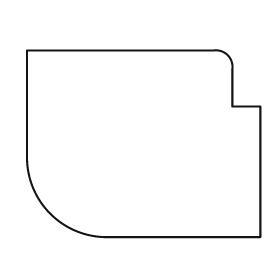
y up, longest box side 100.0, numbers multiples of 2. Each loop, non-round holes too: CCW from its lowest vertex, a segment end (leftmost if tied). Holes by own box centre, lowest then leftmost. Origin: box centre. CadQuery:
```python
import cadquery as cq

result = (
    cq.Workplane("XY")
    .moveTo(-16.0, -40.0)
    .lineTo(50.0, -40.0)
    .lineTo(50.0, 16.0)
    .lineTo(38.0, 16.0)
    .lineTo(38.0, 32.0)
    .threePointArc((36.0, 38.0), (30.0, 40.0))
    .lineTo(-50.0, 40.0)
    .lineTo(-50.0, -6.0)
    .threePointArc((-40.0, -30.0), (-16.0, -40.0))
    .close()
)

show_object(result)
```